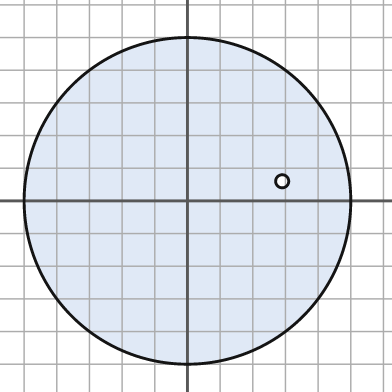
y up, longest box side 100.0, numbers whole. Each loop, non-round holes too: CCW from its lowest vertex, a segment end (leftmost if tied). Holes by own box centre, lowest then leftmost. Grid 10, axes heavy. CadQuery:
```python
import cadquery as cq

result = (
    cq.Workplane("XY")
    .moveTo(0.0, 0.0)
    .circle(50.0)
    .moveTo(29.0, 6.0)
    .circle(2.0)
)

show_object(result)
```